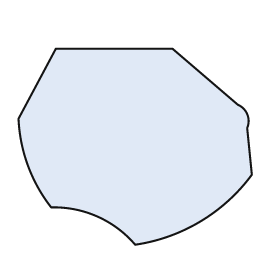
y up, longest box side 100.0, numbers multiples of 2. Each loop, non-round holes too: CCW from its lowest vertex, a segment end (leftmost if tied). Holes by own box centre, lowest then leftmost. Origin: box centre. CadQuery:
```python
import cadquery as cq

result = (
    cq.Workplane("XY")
    .moveTo(0.0, -42.0)
    .threePointArc((28.0, -32.0), (50.0, -12.0))
    .lineTo(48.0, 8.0)
    .threePointArc((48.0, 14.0), (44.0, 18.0))
    .lineTo(16.0, 42.0)
    .lineTo(-34.0, 42.0)
    .lineTo(-50.0, 12.0)
    .threePointArc((-46.0, -8.0), (-36.0, -26.0))
    .threePointArc((-16.0, -30.0), (0.0, -42.0))
    .close()
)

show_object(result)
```